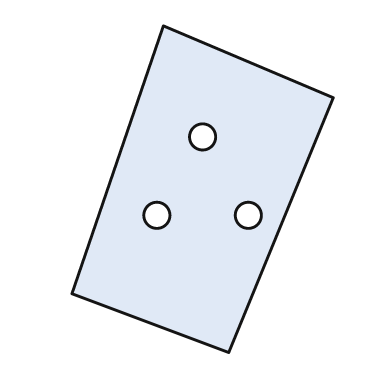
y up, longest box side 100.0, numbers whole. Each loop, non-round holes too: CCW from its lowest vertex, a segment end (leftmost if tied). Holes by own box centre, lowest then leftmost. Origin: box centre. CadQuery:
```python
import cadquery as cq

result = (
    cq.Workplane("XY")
    .moveTo(8.0, -50.0)
    .lineTo(40.0, 28.0)
    .lineTo(-12.0, 50.0)
    .lineTo(-40.0, -32.0)
    .close()
    .moveTo(-14.0, -8.0)
    .circle(4.0)
    .moveTo(14.0, -8.0)
    .circle(4.0)
    .moveTo(0.0, 16.0)
    .circle(4.0)
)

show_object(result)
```